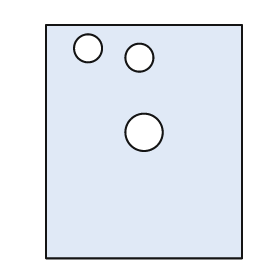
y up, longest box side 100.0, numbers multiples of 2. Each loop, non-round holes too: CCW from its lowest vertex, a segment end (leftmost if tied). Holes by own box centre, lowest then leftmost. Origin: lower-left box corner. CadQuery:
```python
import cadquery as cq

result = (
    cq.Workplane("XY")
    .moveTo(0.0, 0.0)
    .lineTo(84.0, 0.0)
    .lineTo(84.0, 100.0)
    .lineTo(0.0, 100.0)
    .close()
    .moveTo(42.0, 54.0)
    .circle(8.0)
    .moveTo(40.0, 86.0)
    .circle(6.0)
    .moveTo(18.0, 90.0)
    .circle(6.0)
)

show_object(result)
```